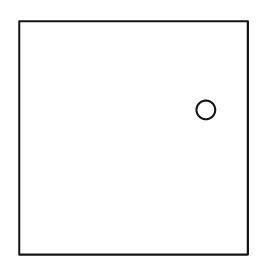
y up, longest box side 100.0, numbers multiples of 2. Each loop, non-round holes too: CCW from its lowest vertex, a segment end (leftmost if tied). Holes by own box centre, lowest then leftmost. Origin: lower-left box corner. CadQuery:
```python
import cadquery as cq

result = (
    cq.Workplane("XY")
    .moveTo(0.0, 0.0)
    .lineTo(98.0, 0.0)
    .lineTo(98.0, 100.0)
    .lineTo(0.0, 100.0)
    .close()
    .moveTo(80.0, 62.0)
    .circle(4.0)
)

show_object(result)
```